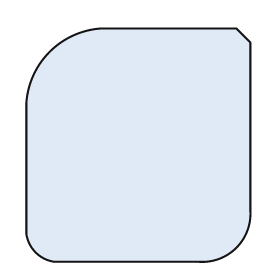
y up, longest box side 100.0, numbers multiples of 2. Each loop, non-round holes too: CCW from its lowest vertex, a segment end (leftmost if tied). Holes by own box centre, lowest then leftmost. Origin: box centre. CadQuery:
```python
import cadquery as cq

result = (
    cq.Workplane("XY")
    .moveTo(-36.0, -50.0)
    .lineTo(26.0, -50.0)
    .threePointArc((42.0, -44.0), (48.0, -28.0))
    .lineTo(48.0, 44.0)
    .lineTo(42.0, 50.0)
    .lineTo(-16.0, 50.0)
    .threePointArc((-38.0, 40.0), (-48.0, 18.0))
    .lineTo(-48.0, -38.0)
    .threePointArc((-44.0, -46.0), (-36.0, -50.0))
    .close()
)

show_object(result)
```